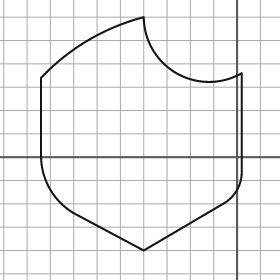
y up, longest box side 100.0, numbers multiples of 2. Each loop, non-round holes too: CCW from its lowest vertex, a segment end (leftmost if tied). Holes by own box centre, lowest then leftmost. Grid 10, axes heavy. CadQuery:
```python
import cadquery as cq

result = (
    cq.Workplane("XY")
    .moveTo(-40.0, -40.0)
    .lineTo(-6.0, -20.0)
    .threePointArc((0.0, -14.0), (2.0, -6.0))
    .lineTo(2.0, 36.0)
    .threePointArc((-26.0, 36.0), (-40.0, 60.0))
    .threePointArc((-64.0, 50.0), (-84.0, 34.0))
    .lineTo(-84.0, 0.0)
    .threePointArc((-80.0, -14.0), (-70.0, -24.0))
    .close()
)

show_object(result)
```